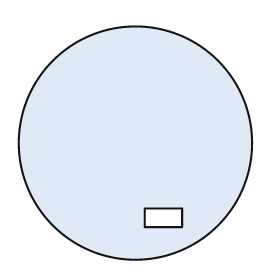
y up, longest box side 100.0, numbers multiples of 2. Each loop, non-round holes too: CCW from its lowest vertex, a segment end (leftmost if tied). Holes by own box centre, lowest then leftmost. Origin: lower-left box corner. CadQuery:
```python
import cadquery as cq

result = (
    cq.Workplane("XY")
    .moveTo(50.0, 50.0)
    .circle(50.0)
    .moveTo(54.0, 14.0)
    .lineTo(70.0, 14.0)
    .lineTo(70.0, 22.0)
    .lineTo(54.0, 22.0)
    .close()
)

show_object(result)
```